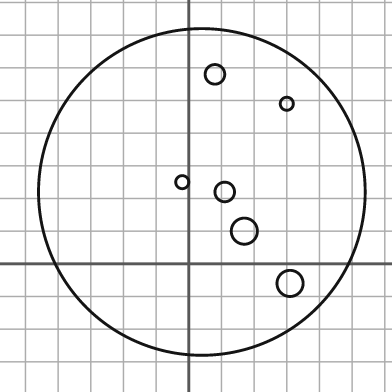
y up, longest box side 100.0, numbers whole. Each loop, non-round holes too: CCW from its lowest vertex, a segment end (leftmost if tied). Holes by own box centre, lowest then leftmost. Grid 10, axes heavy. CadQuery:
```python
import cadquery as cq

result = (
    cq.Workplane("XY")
    .moveTo(4.0, 22.0)
    .circle(50.0)
    .moveTo(31.0, -6.0)
    .circle(4.0)
    .moveTo(17.0, 10.0)
    .circle(4.0)
    .moveTo(11.0, 22.0)
    .circle(3.0)
    .moveTo(-2.0, 25.0)
    .circle(2.0)
    .moveTo(30.0, 49.0)
    .circle(2.0)
    .moveTo(8.0, 58.0)
    .circle(3.0)
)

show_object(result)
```